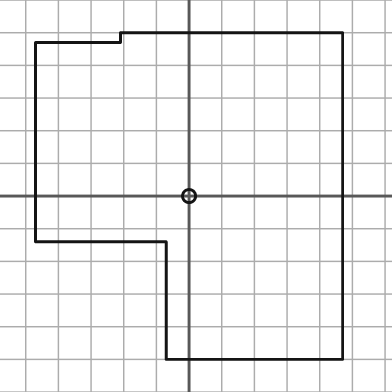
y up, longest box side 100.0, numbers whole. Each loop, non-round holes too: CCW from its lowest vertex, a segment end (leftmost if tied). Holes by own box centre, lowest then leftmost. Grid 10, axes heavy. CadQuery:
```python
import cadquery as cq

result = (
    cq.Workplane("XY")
    .moveTo(-7.0, -50.0)
    .lineTo(47.0, -50.0)
    .lineTo(47.0, 50.0)
    .lineTo(-21.0, 50.0)
    .lineTo(-21.0, 47.0)
    .lineTo(-47.0, 47.0)
    .lineTo(-47.0, -14.0)
    .lineTo(-7.0, -14.0)
    .close()
    .moveTo(0.0, 0.0)
    .circle(2.0)
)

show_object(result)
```